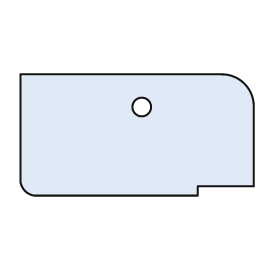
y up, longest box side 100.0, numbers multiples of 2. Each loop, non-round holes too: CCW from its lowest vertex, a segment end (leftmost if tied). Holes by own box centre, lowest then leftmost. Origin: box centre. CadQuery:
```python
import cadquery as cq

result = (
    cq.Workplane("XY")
    .moveTo(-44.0, -26.0)
    .lineTo(26.0, -26.0)
    .lineTo(26.0, -22.0)
    .lineTo(50.0, -22.0)
    .lineTo(50.0, 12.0)
    .threePointArc((46.0, 22.0), (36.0, 26.0))
    .lineTo(-50.0, 26.0)
    .lineTo(-50.0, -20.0)
    .threePointArc((-48.0, -24.0), (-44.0, -26.0))
    .close()
    .moveTo(2.0, 12.0)
    .circle(4.0)
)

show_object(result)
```